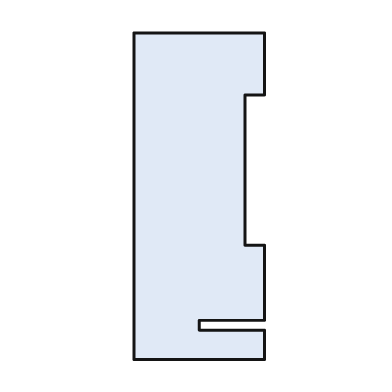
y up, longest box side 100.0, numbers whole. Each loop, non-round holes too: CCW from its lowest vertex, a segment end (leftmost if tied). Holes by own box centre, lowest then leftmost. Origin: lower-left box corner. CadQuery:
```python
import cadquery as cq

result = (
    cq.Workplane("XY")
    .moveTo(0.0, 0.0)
    .lineTo(40.0, 0.0)
    .lineTo(40.0, 9.0)
    .lineTo(20.0, 9.0)
    .lineTo(20.0, 12.0)
    .lineTo(40.0, 12.0)
    .lineTo(40.0, 35.0)
    .lineTo(34.0, 35.0)
    .lineTo(34.0, 81.0)
    .lineTo(40.0, 81.0)
    .lineTo(40.0, 100.0)
    .lineTo(0.0, 100.0)
    .close()
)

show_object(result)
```